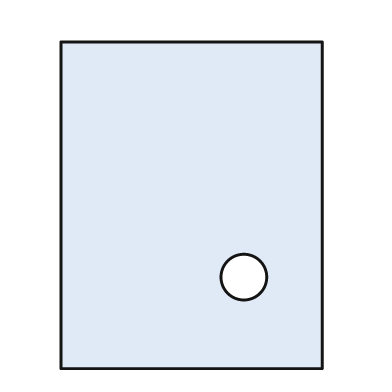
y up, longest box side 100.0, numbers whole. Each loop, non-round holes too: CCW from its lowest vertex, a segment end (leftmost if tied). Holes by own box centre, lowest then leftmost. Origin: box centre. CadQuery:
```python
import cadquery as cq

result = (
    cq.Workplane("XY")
    .moveTo(-40.0, -50.0)
    .lineTo(40.0, -50.0)
    .lineTo(40.0, 50.0)
    .lineTo(-40.0, 50.0)
    .close()
    .moveTo(16.0, -22.0)
    .circle(7.0)
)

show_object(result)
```